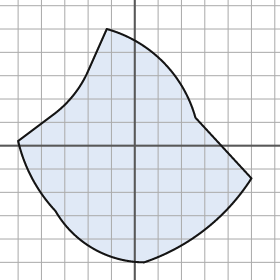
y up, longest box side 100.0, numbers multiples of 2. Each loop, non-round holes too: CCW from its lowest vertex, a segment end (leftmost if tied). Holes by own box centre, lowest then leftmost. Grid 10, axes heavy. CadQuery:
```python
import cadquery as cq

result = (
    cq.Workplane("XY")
    .moveTo(4.0, -50.0)
    .threePointArc((30.0, -36.0), (50.0, -14.0))
    .lineTo(26.0, 12.0)
    .threePointArc((12.0, 36.0), (-12.0, 50.0))
    .lineTo(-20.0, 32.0)
    .threePointArc((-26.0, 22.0), (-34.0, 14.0))
    .lineTo(-50.0, 2.0)
    .threePointArc((-44.0, -14.0), (-34.0, -28.0))
    .threePointArc((-18.0, -44.0), (4.0, -50.0))
    .close()
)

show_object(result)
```